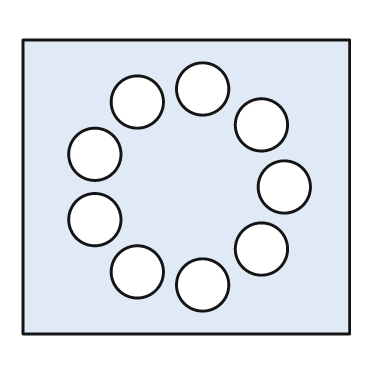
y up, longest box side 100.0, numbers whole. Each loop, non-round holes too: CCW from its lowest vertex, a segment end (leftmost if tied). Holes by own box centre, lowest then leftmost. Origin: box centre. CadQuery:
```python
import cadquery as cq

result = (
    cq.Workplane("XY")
    .moveTo(-50.0, -45.0)
    .lineTo(50.0, -45.0)
    .lineTo(50.0, 45.0)
    .lineTo(-50.0, 45.0)
    .close()
    .moveTo(5.0, -30.0)
    .circle(8.0)
    .moveTo(-15.0, -26.0)
    .circle(8.0)
    .moveTo(23.0, -19.0)
    .circle(8.0)
    .moveTo(-28.0, -10.0)
    .circle(8.0)
    .moveTo(30.0, 0.0)
    .circle(8.0)
    .moveTo(-28.0, 10.0)
    .circle(8.0)
    .moveTo(23.0, 19.0)
    .circle(8.0)
    .moveTo(-15.0, 26.0)
    .circle(8.0)
    .moveTo(5.0, 30.0)
    .circle(8.0)
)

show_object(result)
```